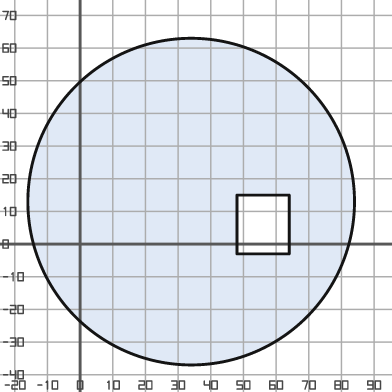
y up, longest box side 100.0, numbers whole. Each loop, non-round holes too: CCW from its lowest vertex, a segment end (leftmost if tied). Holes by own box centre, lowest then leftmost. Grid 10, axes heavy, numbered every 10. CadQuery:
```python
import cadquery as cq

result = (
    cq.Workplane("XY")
    .moveTo(34.0, 13.0)
    .circle(50.0)
    .moveTo(48.0, -3.0)
    .lineTo(64.0, -3.0)
    .lineTo(64.0, 15.0)
    .lineTo(48.0, 15.0)
    .close()
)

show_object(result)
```